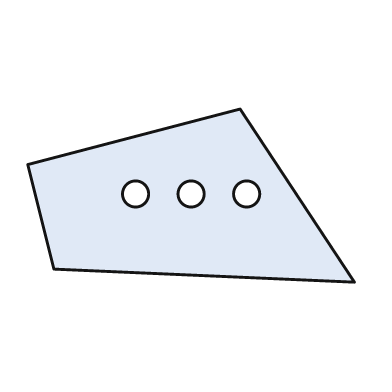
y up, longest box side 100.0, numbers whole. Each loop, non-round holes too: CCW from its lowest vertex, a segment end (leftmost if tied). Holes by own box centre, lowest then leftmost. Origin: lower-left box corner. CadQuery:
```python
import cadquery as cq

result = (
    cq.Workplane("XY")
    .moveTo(100.0, 0.0)
    .lineTo(65.0, 53.0)
    .lineTo(0.0, 36.0)
    .lineTo(8.0, 4.0)
    .close()
    .moveTo(33.0, 27.0)
    .circle(4.0)
    .moveTo(50.0, 27.0)
    .circle(4.0)
    .moveTo(67.0, 27.0)
    .circle(4.0)
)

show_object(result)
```